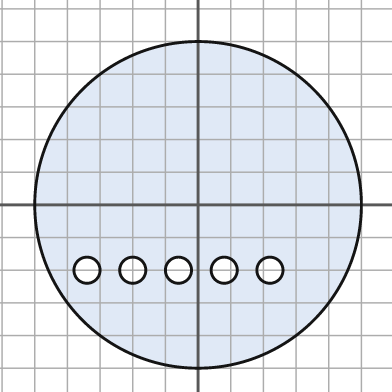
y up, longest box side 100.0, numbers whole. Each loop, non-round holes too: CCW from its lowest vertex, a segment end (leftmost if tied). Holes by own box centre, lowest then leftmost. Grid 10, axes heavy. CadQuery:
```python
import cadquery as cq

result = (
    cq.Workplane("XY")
    .moveTo(0.0, 0.0)
    .circle(50.0)
    .moveTo(-34.0, -20.0)
    .circle(4.0)
    .moveTo(-20.0, -20.0)
    .circle(4.0)
    .moveTo(-6.0, -20.0)
    .circle(4.0)
    .moveTo(8.0, -20.0)
    .circle(4.0)
    .moveTo(22.0, -20.0)
    .circle(4.0)
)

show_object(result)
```